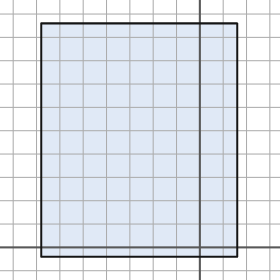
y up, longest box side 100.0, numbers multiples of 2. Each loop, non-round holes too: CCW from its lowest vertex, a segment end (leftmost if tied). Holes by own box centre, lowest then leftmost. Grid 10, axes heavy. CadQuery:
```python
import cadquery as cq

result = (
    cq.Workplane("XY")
    .moveTo(-68.0, -4.0)
    .lineTo(16.0, -4.0)
    .lineTo(16.0, 96.0)
    .lineTo(-68.0, 96.0)
    .close()
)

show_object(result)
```